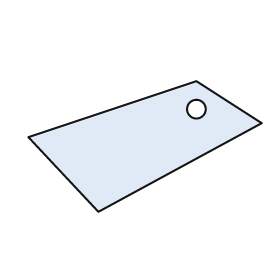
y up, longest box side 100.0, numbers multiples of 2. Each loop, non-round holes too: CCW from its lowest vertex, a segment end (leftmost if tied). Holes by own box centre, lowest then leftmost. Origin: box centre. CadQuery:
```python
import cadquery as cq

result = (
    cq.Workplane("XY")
    .moveTo(-20.0, -28.0)
    .lineTo(50.0, 10.0)
    .lineTo(22.0, 28.0)
    .lineTo(-50.0, 4.0)
    .close()
    .moveTo(22.0, 16.0)
    .circle(4.0)
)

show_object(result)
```